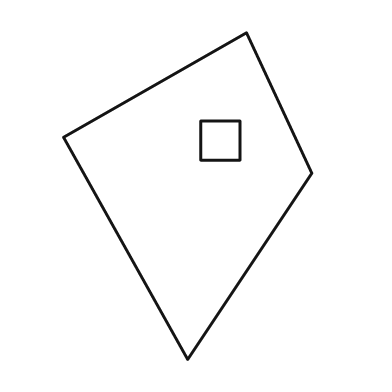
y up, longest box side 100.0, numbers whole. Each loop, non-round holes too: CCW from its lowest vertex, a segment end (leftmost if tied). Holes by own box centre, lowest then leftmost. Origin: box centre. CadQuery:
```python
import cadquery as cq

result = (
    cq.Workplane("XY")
    .moveTo(0.0, -50.0)
    .lineTo(38.0, 7.0)
    .lineTo(18.0, 50.0)
    .lineTo(-38.0, 18.0)
    .close()
    .moveTo(4.0, 11.0)
    .lineTo(16.0, 11.0)
    .lineTo(16.0, 23.0)
    .lineTo(4.0, 23.0)
    .close()
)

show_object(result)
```